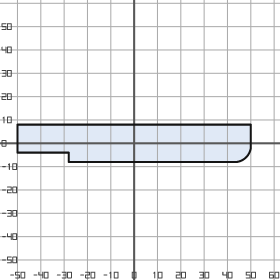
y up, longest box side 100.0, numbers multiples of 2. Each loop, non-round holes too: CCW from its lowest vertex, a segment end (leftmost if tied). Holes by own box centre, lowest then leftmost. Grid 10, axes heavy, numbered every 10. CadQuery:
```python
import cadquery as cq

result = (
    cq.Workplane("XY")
    .moveTo(-28.0, -8.0)
    .lineTo(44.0, -8.0)
    .threePointArc((48.0, -6.0), (50.0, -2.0))
    .lineTo(50.0, 8.0)
    .lineTo(-50.0, 8.0)
    .lineTo(-50.0, -4.0)
    .lineTo(-28.0, -4.0)
    .close()
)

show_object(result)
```